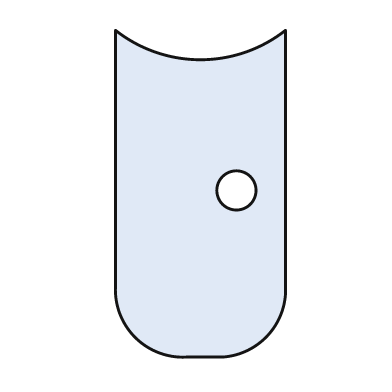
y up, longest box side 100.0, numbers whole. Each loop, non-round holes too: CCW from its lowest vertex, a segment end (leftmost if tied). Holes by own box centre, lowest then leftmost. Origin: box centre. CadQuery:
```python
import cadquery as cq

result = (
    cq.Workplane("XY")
    .moveTo(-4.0, -50.0)
    .lineTo(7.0, -50.0)
    .threePointArc((20.0, -44.0), (26.0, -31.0))
    .lineTo(26.0, 50.0)
    .threePointArc((0.0, 41.0), (-26.0, 50.0))
    .lineTo(-26.0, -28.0)
    .threePointArc((-20.0, -44.0), (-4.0, -50.0))
    .close()
    .moveTo(11.0, 1.0)
    .circle(6.0)
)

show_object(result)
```